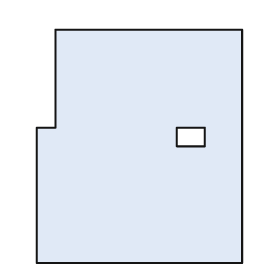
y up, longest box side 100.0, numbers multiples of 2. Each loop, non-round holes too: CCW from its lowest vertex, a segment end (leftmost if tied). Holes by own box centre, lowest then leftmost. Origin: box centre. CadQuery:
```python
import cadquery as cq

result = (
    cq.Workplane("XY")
    .moveTo(-44.0, -50.0)
    .lineTo(44.0, -50.0)
    .lineTo(44.0, 50.0)
    .lineTo(-36.0, 50.0)
    .lineTo(-36.0, 8.0)
    .lineTo(-44.0, 8.0)
    .close()
    .moveTo(16.0, 0.0)
    .lineTo(28.0, 0.0)
    .lineTo(28.0, 8.0)
    .lineTo(16.0, 8.0)
    .close()
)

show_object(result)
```